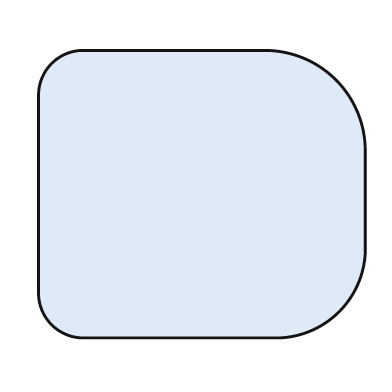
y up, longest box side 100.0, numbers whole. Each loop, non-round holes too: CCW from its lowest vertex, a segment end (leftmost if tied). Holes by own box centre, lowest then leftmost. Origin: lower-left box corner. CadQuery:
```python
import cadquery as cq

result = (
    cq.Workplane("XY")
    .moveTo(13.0, 0.0)
    .lineTo(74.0, 0.0)
    .threePointArc((92.0, 8.0), (100.0, 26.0))
    .lineTo(100.0, 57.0)
    .threePointArc((91.0, 79.0), (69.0, 88.0))
    .lineTo(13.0, 88.0)
    .threePointArc((4.0, 84.0), (0.0, 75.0))
    .lineTo(0.0, 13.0)
    .threePointArc((4.0, 4.0), (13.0, 0.0))
    .close()
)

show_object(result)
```